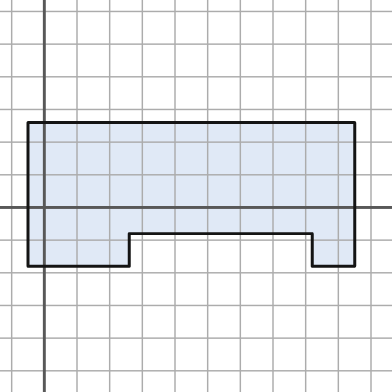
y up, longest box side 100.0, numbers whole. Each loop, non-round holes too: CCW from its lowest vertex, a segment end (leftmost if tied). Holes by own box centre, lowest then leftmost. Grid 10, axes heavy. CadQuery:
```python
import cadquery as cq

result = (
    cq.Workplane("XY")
    .moveTo(-5.0, -18.0)
    .lineTo(26.0, -18.0)
    .lineTo(26.0, -8.0)
    .lineTo(82.0, -8.0)
    .lineTo(82.0, -18.0)
    .lineTo(95.0, -18.0)
    .lineTo(95.0, 26.0)
    .lineTo(-5.0, 26.0)
    .close()
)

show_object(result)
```